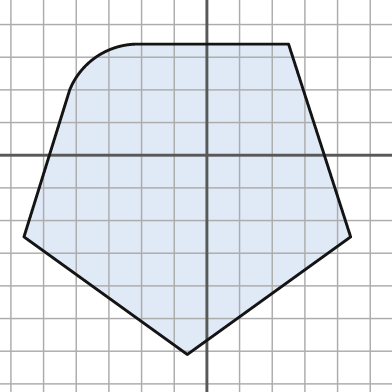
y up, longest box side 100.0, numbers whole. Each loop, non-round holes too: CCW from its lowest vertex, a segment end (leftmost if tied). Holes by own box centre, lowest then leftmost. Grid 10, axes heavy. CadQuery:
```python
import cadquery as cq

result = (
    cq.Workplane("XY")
    .moveTo(-6.0, -61.0)
    .lineTo(44.0, -25.0)
    .lineTo(25.0, 34.0)
    .lineTo(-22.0, 34.0)
    .threePointArc((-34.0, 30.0), (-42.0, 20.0))
    .lineTo(-56.0, -25.0)
    .close()
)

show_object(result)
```